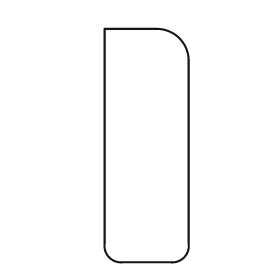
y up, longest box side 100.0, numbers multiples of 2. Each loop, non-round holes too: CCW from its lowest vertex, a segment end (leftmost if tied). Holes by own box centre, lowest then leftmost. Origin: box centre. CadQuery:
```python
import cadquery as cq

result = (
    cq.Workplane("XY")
    .moveTo(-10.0, -50.0)
    .lineTo(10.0, -50.0)
    .threePointArc((16.0, -48.0), (18.0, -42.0))
    .lineTo(18.0, 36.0)
    .threePointArc((14.0, 46.0), (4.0, 50.0))
    .lineTo(-18.0, 50.0)
    .lineTo(-18.0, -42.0)
    .threePointArc((-16.0, -48.0), (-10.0, -50.0))
    .close()
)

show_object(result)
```